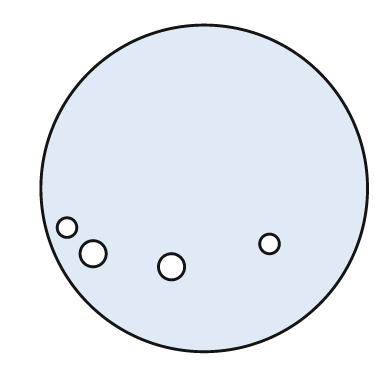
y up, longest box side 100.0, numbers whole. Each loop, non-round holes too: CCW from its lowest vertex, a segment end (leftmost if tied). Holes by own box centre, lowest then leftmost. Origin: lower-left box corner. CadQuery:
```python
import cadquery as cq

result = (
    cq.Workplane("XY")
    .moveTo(50.0, 50.0)
    .circle(50.0)
    .moveTo(40.0, 26.0)
    .circle(4.0)
    .moveTo(16.0, 30.0)
    .circle(4.0)
    .moveTo(70.0, 33.0)
    .circle(3.0)
    .moveTo(8.0, 38.0)
    .circle(3.0)
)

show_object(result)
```